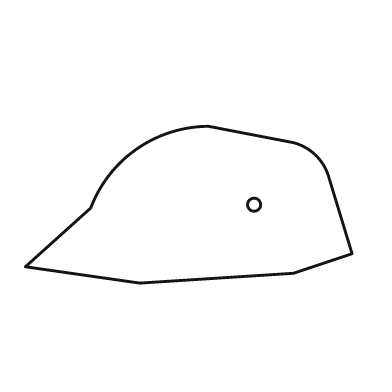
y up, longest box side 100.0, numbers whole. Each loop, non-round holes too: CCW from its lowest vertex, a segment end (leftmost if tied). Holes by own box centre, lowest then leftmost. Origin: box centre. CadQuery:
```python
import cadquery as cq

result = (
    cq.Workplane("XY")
    .moveTo(-15.0, -24.0)
    .lineTo(32.0, -21.0)
    .lineTo(50.0, -15.0)
    .lineTo(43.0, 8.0)
    .threePointArc((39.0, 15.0), (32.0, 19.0))
    .lineTo(6.0, 24.0)
    .threePointArc((-16.0, 17.0), (-30.0, -1.0))
    .lineTo(-50.0, -19.0)
    .close()
    .moveTo(20.0, 0.0)
    .circle(2.0)
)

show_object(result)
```